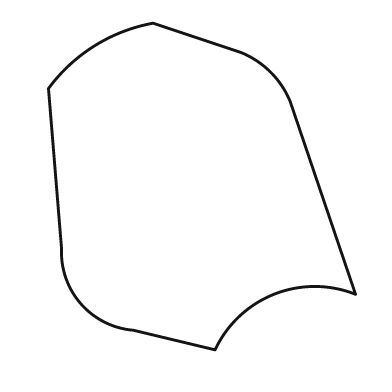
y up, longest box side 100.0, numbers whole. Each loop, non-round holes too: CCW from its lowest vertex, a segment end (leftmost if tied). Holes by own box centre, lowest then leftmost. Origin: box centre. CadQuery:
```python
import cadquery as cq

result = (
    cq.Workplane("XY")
    .moveTo(4.0, -50.0)
    .threePointArc((22.0, -33.0), (47.0, -33.0))
    .lineTo(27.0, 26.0)
    .threePointArc((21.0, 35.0), (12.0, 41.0))
    .lineTo(-15.0, 50.0)
    .threePointArc((-33.0, 43.0), (-47.0, 30.0))
    .lineTo(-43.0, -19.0)
    .threePointArc((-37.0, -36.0), (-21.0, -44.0))
    .close()
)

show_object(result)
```